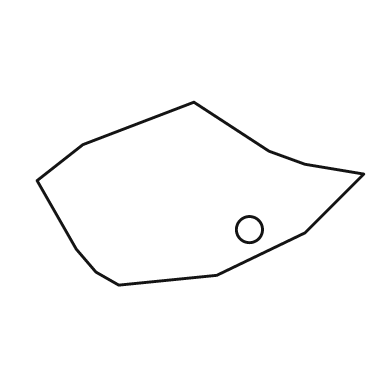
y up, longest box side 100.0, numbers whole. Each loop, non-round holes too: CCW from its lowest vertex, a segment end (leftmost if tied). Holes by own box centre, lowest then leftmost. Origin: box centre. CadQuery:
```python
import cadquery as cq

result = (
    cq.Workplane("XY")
    .moveTo(-25.0, -28.0)
    .lineTo(5.0, -25.0)
    .lineTo(32.0, -12.0)
    .lineTo(50.0, 6.0)
    .lineTo(32.0, 9.0)
    .lineTo(21.0, 13.0)
    .lineTo(-2.0, 28.0)
    .lineTo(-36.0, 15.0)
    .lineTo(-50.0, 4.0)
    .lineTo(-38.0, -17.0)
    .lineTo(-32.0, -24.0)
    .close()
    .moveTo(15.0, -11.0)
    .circle(4.0)
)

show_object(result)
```